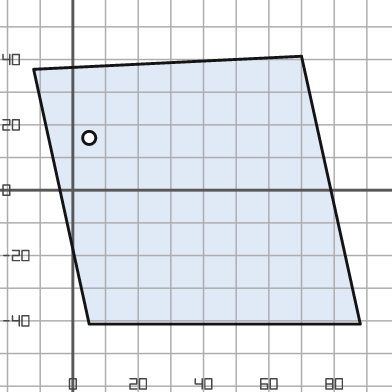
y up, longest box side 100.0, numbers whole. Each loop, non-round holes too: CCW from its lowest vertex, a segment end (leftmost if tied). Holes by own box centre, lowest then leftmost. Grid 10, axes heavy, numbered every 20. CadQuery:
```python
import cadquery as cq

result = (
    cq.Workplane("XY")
    .moveTo(5.0, -41.0)
    .lineTo(88.0, -41.0)
    .lineTo(70.0, 41.0)
    .lineTo(-12.0, 37.0)
    .close()
    .moveTo(5.0, 16.0)
    .circle(2.0)
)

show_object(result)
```